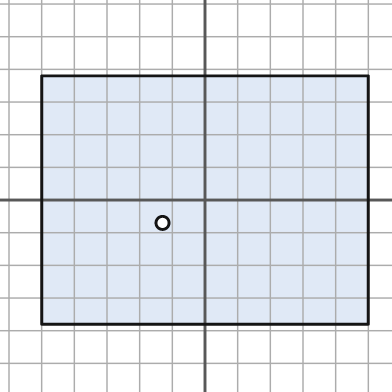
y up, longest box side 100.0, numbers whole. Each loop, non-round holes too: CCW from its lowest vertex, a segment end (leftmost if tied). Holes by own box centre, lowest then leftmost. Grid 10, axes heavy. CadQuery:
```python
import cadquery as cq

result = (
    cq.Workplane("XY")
    .moveTo(-50.0, -38.0)
    .lineTo(50.0, -38.0)
    .lineTo(50.0, 38.0)
    .lineTo(-50.0, 38.0)
    .close()
    .moveTo(-13.0, -7.0)
    .circle(2.0)
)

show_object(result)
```